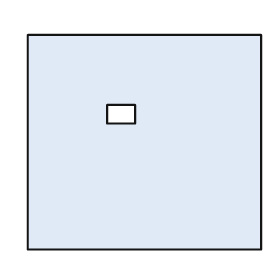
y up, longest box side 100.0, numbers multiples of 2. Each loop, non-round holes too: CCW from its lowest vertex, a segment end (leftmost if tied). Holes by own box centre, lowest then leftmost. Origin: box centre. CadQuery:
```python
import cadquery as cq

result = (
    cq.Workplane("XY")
    .moveTo(-50.0, -46.0)
    .lineTo(50.0, -46.0)
    .lineTo(50.0, 46.0)
    .lineTo(-50.0, 46.0)
    .close()
    .moveTo(-16.0, 8.0)
    .lineTo(-4.0, 8.0)
    .lineTo(-4.0, 16.0)
    .lineTo(-16.0, 16.0)
    .close()
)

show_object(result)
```